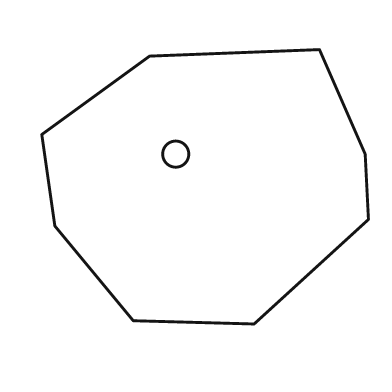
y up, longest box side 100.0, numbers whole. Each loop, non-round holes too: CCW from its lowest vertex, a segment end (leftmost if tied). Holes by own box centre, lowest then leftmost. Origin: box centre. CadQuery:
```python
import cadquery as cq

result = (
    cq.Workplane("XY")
    .moveTo(15.0, -42.0)
    .lineTo(50.0, -10.0)
    .lineTo(49.0, 10.0)
    .lineTo(35.0, 42.0)
    .lineTo(-17.0, 40.0)
    .lineTo(-50.0, 16.0)
    .lineTo(-46.0, -12.0)
    .lineTo(-22.0, -41.0)
    .close()
    .moveTo(-9.0, 10.0)
    .circle(4.0)
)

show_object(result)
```